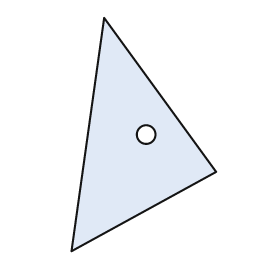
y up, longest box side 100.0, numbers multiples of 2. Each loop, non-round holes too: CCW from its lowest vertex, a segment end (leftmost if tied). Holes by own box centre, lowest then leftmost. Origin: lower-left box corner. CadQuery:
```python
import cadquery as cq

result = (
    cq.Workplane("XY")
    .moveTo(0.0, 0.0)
    .lineTo(62.0, 34.0)
    .lineTo(14.0, 100.0)
    .close()
    .moveTo(32.0, 50.0)
    .circle(4.0)
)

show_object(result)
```